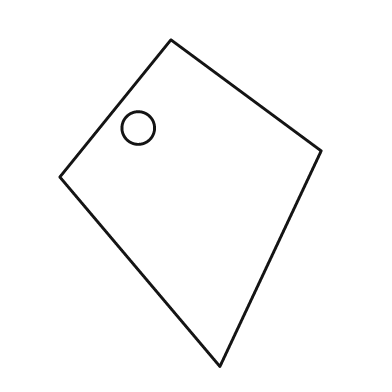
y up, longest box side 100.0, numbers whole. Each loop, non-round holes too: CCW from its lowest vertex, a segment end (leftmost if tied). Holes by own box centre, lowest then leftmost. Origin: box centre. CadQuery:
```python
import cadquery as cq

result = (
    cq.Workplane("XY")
    .moveTo(9.0, -50.0)
    .lineTo(40.0, 16.0)
    .lineTo(-6.0, 50.0)
    .lineTo(-40.0, 8.0)
    .close()
    .moveTo(-16.0, 23.0)
    .circle(5.0)
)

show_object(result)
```